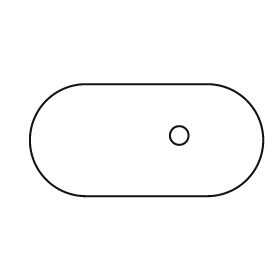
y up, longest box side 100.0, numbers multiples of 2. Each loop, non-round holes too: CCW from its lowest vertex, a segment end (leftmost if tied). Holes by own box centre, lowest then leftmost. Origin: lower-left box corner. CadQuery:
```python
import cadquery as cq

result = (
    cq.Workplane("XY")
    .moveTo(24.0, 0.0)
    .lineTo(76.0, 0.0)
    .threePointArc((100.0, 24.0), (76.0, 48.0))
    .lineTo(24.0, 48.0)
    .threePointArc((0.0, 24.0), (24.0, 0.0))
    .close()
    .moveTo(64.0, 26.0)
    .circle(4.0)
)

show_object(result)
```